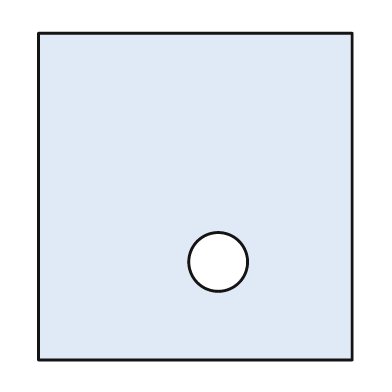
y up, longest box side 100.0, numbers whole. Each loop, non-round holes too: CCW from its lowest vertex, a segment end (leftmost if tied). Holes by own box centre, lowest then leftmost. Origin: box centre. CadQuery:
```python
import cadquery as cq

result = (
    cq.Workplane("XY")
    .moveTo(-48.0, -50.0)
    .lineTo(48.0, -50.0)
    .lineTo(48.0, 50.0)
    .lineTo(-48.0, 50.0)
    .close()
    .moveTo(7.0, -20.0)
    .circle(9.0)
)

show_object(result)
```